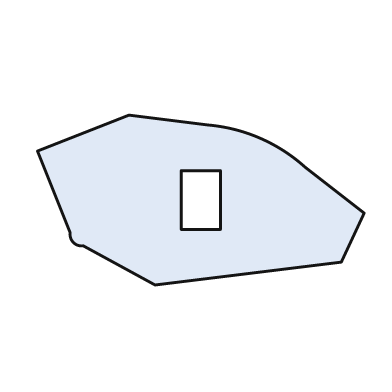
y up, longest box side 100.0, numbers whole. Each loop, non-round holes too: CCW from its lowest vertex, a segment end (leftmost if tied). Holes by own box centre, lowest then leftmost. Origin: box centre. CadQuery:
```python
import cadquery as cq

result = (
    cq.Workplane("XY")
    .moveTo(-14.0, -26.0)
    .lineTo(43.0, -19.0)
    .lineTo(50.0, -4.0)
    .lineTo(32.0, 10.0)
    .threePointArc((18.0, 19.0), (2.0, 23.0))
    .lineTo(-22.0, 26.0)
    .lineTo(-50.0, 15.0)
    .lineTo(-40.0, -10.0)
    .threePointArc((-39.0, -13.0), (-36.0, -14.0))
    .close()
    .moveTo(-6.0, -9.0)
    .lineTo(6.0, -9.0)
    .lineTo(6.0, 9.0)
    .lineTo(-6.0, 9.0)
    .close()
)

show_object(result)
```